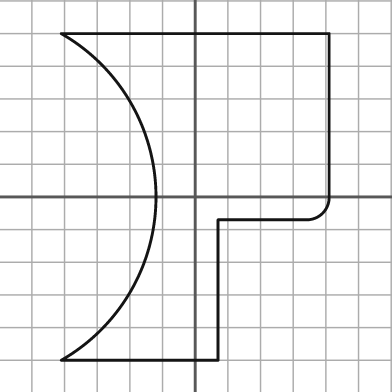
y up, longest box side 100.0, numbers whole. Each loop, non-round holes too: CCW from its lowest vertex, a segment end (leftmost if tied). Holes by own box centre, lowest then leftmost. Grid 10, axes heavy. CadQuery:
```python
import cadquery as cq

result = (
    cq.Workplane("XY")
    .moveTo(-41.0, -50.0)
    .lineTo(7.0, -50.0)
    .lineTo(7.0, -7.0)
    .lineTo(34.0, -7.0)
    .threePointArc((39.0, -5.0), (41.0, 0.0))
    .lineTo(41.0, 50.0)
    .lineTo(-41.0, 50.0)
    .threePointArc((-12.0, 0.0), (-41.0, -50.0))
    .close()
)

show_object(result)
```